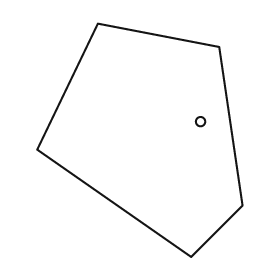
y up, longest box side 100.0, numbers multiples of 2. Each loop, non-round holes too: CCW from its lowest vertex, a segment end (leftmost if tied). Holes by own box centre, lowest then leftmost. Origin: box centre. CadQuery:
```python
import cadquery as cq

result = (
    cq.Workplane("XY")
    .moveTo(22.0, -50.0)
    .lineTo(44.0, -28.0)
    .lineTo(34.0, 40.0)
    .lineTo(-18.0, 50.0)
    .lineTo(-44.0, -4.0)
    .close()
    .moveTo(26.0, 8.0)
    .circle(2.0)
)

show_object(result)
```